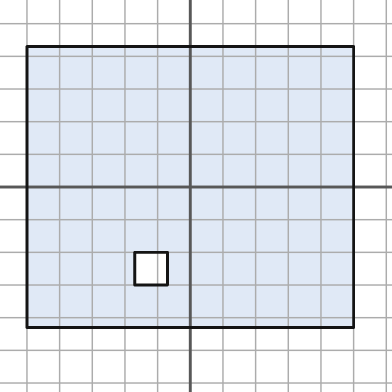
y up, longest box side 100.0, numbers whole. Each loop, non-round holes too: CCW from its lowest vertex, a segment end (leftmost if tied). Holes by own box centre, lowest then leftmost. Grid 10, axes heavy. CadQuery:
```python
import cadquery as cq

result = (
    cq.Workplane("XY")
    .moveTo(-50.0, -43.0)
    .lineTo(50.0, -43.0)
    .lineTo(50.0, 43.0)
    .lineTo(-50.0, 43.0)
    .close()
    .moveTo(-17.0, -30.0)
    .lineTo(-7.0, -30.0)
    .lineTo(-7.0, -20.0)
    .lineTo(-17.0, -20.0)
    .close()
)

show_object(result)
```